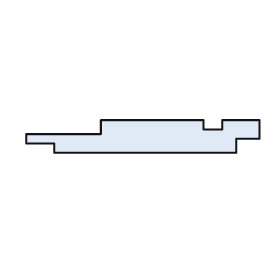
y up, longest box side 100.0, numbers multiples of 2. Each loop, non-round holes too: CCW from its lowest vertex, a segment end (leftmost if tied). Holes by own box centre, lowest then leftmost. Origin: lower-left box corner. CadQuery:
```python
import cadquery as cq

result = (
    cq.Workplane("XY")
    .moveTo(12.0, 0.0)
    .lineTo(90.0, 0.0)
    .lineTo(90.0, 6.0)
    .lineTo(100.0, 6.0)
    .lineTo(100.0, 14.0)
    .lineTo(84.0, 14.0)
    .lineTo(84.0, 10.0)
    .lineTo(76.0, 10.0)
    .lineTo(76.0, 14.0)
    .lineTo(32.0, 14.0)
    .lineTo(32.0, 8.0)
    .lineTo(0.0, 8.0)
    .lineTo(0.0, 4.0)
    .lineTo(12.0, 4.0)
    .close()
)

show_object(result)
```